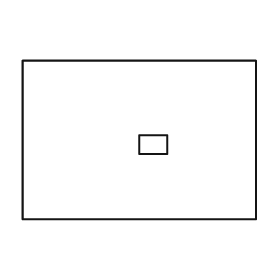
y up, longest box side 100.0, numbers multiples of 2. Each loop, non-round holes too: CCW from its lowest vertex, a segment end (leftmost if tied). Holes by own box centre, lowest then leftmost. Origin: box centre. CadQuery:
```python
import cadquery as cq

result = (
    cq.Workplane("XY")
    .moveTo(-50.0, -34.0)
    .lineTo(50.0, -34.0)
    .lineTo(50.0, 34.0)
    .lineTo(-50.0, 34.0)
    .close()
    .moveTo(0.0, -6.0)
    .lineTo(12.0, -6.0)
    .lineTo(12.0, 2.0)
    .lineTo(0.0, 2.0)
    .close()
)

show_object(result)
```